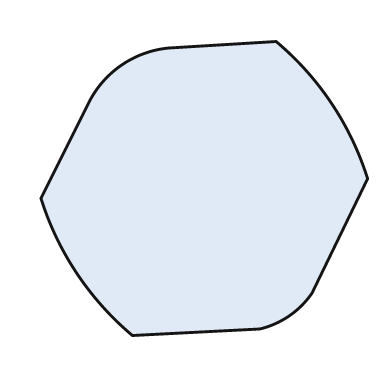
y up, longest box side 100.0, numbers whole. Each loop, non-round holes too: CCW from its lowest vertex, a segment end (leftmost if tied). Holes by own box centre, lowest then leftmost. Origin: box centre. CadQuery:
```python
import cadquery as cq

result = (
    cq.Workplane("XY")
    .moveTo(-22.0, -45.0)
    .lineTo(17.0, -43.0)
    .threePointArc((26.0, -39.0), (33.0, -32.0))
    .lineTo(50.0, 3.0)
    .threePointArc((39.0, 26.0), (22.0, 45.0))
    .lineTo(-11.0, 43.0)
    .threePointArc((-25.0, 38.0), (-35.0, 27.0))
    .lineTo(-50.0, -3.0)
    .threePointArc((-39.0, -26.0), (-22.0, -45.0))
    .close()
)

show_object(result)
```